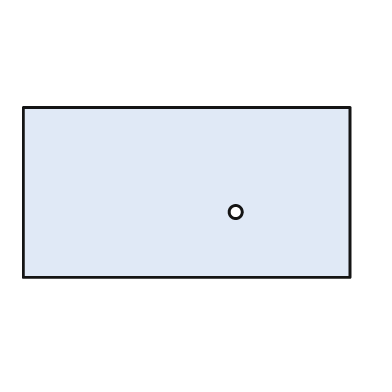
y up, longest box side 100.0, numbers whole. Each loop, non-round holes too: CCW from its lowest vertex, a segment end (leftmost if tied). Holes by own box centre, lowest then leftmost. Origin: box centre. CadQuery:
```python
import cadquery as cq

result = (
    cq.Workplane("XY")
    .moveTo(-50.0, -26.0)
    .lineTo(50.0, -26.0)
    .lineTo(50.0, 26.0)
    .lineTo(-50.0, 26.0)
    .close()
    .moveTo(15.0, -6.0)
    .circle(2.0)
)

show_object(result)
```